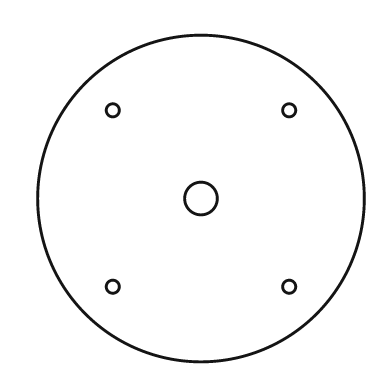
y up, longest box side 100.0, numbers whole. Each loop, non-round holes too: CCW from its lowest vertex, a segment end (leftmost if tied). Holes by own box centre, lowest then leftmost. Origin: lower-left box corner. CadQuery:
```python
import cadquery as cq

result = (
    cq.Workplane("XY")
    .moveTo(50.0, 50.0)
    .circle(50.0)
    .moveTo(23.0, 23.0)
    .circle(2.0)
    .moveTo(77.0, 23.0)
    .circle(2.0)
    .moveTo(50.0, 50.0)
    .circle(5.0)
    .moveTo(23.0, 77.0)
    .circle(2.0)
    .moveTo(77.0, 77.0)
    .circle(2.0)
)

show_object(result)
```